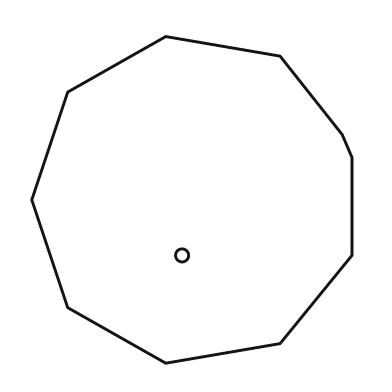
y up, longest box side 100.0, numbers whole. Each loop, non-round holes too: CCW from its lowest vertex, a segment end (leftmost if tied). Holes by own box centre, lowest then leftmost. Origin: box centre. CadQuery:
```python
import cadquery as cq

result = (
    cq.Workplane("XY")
    .moveTo(-8.0, -50.0)
    .lineTo(27.0, -44.0)
    .lineTo(49.0, -17.0)
    .lineTo(49.0, 13.0)
    .lineTo(46.0, 20.0)
    .lineTo(27.0, 44.0)
    .lineTo(-8.0, 50.0)
    .lineTo(-38.0, 33.0)
    .lineTo(-49.0, 0.0)
    .lineTo(-38.0, -33.0)
    .close()
    .moveTo(-3.0, -17.0)
    .circle(2.0)
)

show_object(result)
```